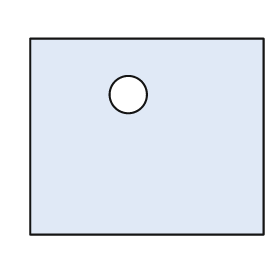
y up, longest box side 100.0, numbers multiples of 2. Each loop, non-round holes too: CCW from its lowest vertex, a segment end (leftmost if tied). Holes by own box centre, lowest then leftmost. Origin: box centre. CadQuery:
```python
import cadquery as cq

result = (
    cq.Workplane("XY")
    .moveTo(-50.0, -42.0)
    .lineTo(50.0, -42.0)
    .lineTo(50.0, 42.0)
    .lineTo(-50.0, 42.0)
    .close()
    .moveTo(-8.0, 18.0)
    .circle(8.0)
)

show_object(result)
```